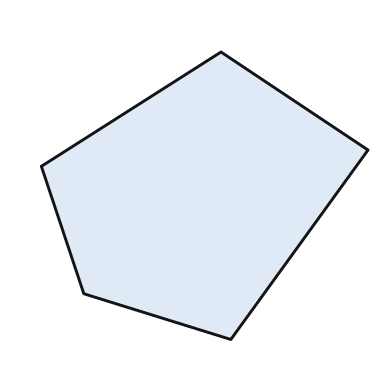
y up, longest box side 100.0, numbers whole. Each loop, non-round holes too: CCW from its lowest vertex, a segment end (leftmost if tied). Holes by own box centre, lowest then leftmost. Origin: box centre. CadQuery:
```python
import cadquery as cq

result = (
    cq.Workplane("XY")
    .moveTo(8.0, -44.0)
    .lineTo(50.0, 14.0)
    .lineTo(5.0, 44.0)
    .lineTo(-50.0, 9.0)
    .lineTo(-37.0, -30.0)
    .close()
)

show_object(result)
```